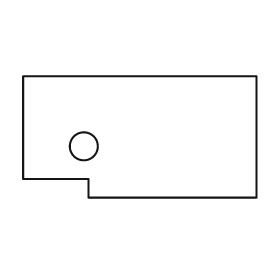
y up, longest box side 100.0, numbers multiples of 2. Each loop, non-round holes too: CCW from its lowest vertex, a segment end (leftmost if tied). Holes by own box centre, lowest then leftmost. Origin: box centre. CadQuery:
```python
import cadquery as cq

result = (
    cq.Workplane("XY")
    .moveTo(-22.0, -26.0)
    .lineTo(50.0, -26.0)
    .lineTo(50.0, 26.0)
    .lineTo(-50.0, 26.0)
    .lineTo(-50.0, -18.0)
    .lineTo(-22.0, -18.0)
    .close()
    .moveTo(-24.0, -4.0)
    .circle(6.0)
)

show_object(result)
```